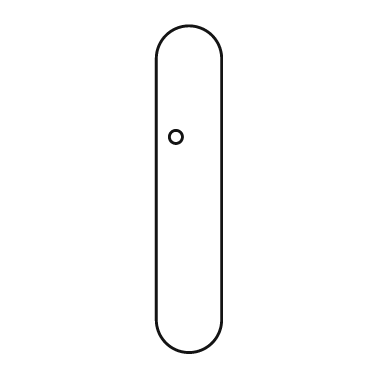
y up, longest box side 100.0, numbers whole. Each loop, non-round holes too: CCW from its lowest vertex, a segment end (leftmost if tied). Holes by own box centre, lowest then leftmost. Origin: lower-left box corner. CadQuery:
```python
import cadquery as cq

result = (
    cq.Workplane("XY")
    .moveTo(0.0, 10.0)
    .threePointArc((10.0, 0.0), (20.0, 10.0))
    .lineTo(20.0, 90.0)
    .threePointArc((10.0, 100.0), (0.0, 90.0))
    .close()
    .moveTo(6.0, 66.0)
    .circle(2.0)
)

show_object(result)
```